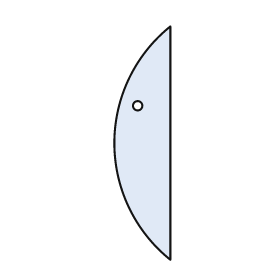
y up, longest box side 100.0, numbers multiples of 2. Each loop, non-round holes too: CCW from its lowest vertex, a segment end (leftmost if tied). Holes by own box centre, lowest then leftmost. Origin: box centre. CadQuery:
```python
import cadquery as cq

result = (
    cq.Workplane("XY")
    .moveTo(12.0, -50.0)
    .lineTo(12.0, 50.0)
    .threePointArc((-12.0, 0.0), (12.0, -50.0))
    .close()
    .moveTo(-2.0, 16.0)
    .circle(2.0)
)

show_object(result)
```